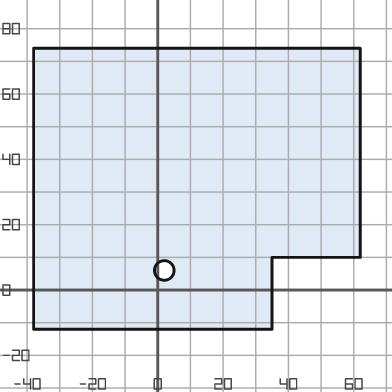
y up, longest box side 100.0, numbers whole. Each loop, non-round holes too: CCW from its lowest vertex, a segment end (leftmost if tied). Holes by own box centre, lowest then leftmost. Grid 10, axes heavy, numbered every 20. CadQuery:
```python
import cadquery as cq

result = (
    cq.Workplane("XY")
    .moveTo(-38.0, -12.0)
    .lineTo(35.0, -12.0)
    .lineTo(35.0, 10.0)
    .lineTo(62.0, 10.0)
    .lineTo(62.0, 74.0)
    .lineTo(-38.0, 74.0)
    .close()
    .moveTo(2.0, 6.0)
    .circle(3.0)
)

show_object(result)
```